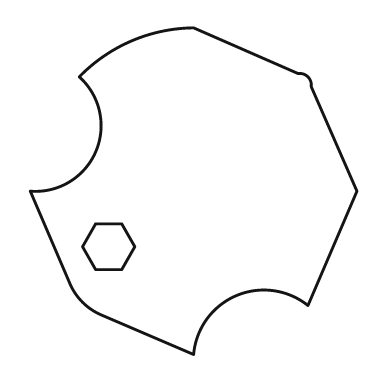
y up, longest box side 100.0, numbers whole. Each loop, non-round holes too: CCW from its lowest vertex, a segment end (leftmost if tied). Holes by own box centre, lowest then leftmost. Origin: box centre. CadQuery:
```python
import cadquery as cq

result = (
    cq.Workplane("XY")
    .moveTo(0.0, -50.0)
    .threePointArc((13.0, -32.0), (35.0, -35.0))
    .lineTo(50.0, 0.0)
    .lineTo(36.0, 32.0)
    .threePointArc((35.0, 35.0), (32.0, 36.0))
    .lineTo(0.0, 50.0)
    .threePointArc((-19.0, 46.0), (-35.0, 35.0))
    .threePointArc((-30.0, 12.0), (-50.0, 0.0))
    .lineTo(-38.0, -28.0)
    .threePointArc((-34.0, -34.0), (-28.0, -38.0))
    .close()
    .moveTo(-30.0, -24.0)
    .lineTo(-22.0, -24.0)
    .lineTo(-18.0, -17.0)
    .lineTo(-22.0, -10.0)
    .lineTo(-30.0, -10.0)
    .lineTo(-34.0, -17.0)
    .close()
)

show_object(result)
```